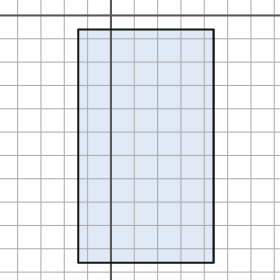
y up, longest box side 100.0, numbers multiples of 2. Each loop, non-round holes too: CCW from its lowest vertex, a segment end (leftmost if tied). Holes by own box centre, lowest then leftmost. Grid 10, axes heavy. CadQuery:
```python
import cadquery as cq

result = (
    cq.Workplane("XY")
    .moveTo(-14.0, -106.0)
    .lineTo(44.0, -106.0)
    .lineTo(44.0, -6.0)
    .lineTo(-14.0, -6.0)
    .close()
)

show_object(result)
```